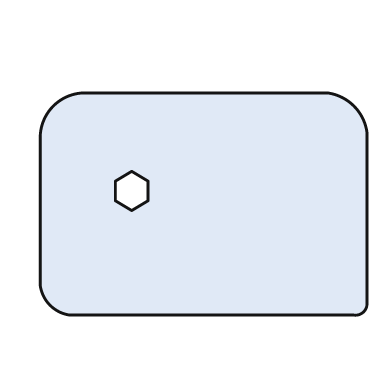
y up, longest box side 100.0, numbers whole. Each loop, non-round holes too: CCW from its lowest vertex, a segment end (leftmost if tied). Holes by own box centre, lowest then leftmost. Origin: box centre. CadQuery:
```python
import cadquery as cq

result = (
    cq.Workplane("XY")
    .moveTo(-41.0, -34.0)
    .lineTo(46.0, -34.0)
    .threePointArc((49.0, -33.0), (50.0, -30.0))
    .lineTo(50.0, 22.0)
    .threePointArc((46.0, 30.0), (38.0, 34.0))
    .lineTo(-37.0, 34.0)
    .threePointArc((-46.0, 30.0), (-50.0, 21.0))
    .lineTo(-50.0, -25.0)
    .threePointArc((-47.0, -31.0), (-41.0, -34.0))
    .close()
    .moveTo(-22.0, -2.0)
    .lineTo(-17.0, 1.0)
    .lineTo(-17.0, 7.0)
    .lineTo(-22.0, 10.0)
    .lineTo(-27.0, 7.0)
    .lineTo(-27.0, 1.0)
    .close()
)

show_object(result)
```